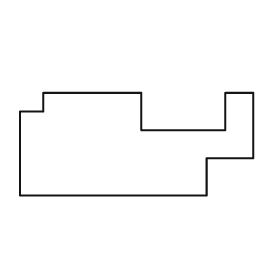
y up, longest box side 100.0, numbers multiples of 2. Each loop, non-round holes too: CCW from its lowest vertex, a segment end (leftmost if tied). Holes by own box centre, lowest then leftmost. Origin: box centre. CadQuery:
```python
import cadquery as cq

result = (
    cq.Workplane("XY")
    .moveTo(-50.0, -22.0)
    .lineTo(30.0, -22.0)
    .lineTo(30.0, -6.0)
    .lineTo(50.0, -6.0)
    .lineTo(50.0, 22.0)
    .lineTo(38.0, 22.0)
    .lineTo(38.0, 6.0)
    .lineTo(2.0, 6.0)
    .lineTo(2.0, 22.0)
    .lineTo(-40.0, 22.0)
    .lineTo(-40.0, 14.0)
    .lineTo(-50.0, 14.0)
    .close()
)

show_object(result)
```